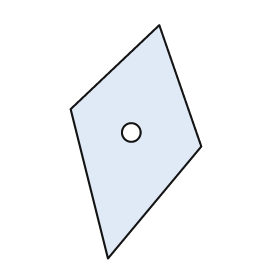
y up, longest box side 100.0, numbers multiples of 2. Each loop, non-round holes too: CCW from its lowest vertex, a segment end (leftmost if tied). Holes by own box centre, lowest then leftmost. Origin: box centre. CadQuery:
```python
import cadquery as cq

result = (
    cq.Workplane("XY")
    .moveTo(-12.0, -50.0)
    .lineTo(28.0, -2.0)
    .lineTo(10.0, 50.0)
    .lineTo(-28.0, 14.0)
    .close()
    .moveTo(-2.0, 4.0)
    .circle(4.0)
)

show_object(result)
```